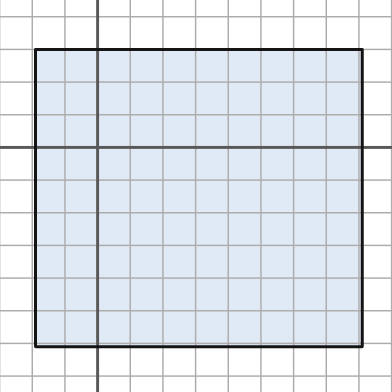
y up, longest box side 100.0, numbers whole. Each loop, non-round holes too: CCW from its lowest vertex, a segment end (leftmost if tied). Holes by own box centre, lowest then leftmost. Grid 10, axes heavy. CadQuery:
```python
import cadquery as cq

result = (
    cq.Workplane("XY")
    .moveTo(-19.0, -61.0)
    .lineTo(81.0, -61.0)
    .lineTo(81.0, 30.0)
    .lineTo(-19.0, 30.0)
    .close()
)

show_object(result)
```